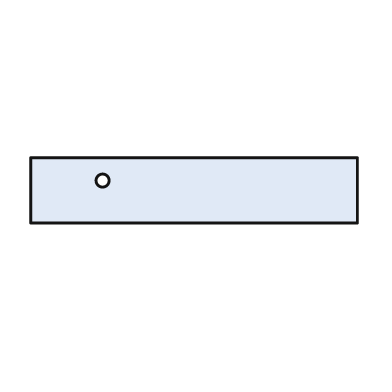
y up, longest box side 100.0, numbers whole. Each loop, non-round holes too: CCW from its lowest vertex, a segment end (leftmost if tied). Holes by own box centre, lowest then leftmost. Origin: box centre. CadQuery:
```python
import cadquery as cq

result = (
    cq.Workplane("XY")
    .moveTo(-50.0, -10.0)
    .lineTo(50.0, -10.0)
    .lineTo(50.0, 10.0)
    .lineTo(-50.0, 10.0)
    .close()
    .moveTo(-28.0, 3.0)
    .circle(2.0)
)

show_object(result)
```